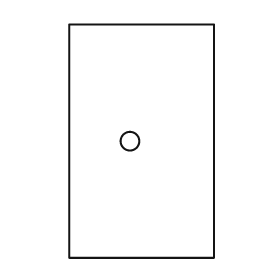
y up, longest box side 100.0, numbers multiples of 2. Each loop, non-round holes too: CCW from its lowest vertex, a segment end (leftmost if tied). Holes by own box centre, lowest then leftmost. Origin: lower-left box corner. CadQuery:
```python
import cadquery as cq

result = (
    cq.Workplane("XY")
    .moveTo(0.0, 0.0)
    .lineTo(62.0, 0.0)
    .lineTo(62.0, 100.0)
    .lineTo(0.0, 100.0)
    .close()
    .moveTo(26.0, 50.0)
    .circle(4.0)
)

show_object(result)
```